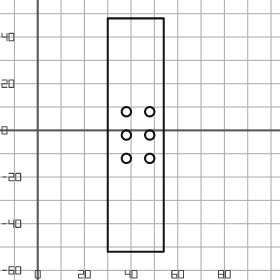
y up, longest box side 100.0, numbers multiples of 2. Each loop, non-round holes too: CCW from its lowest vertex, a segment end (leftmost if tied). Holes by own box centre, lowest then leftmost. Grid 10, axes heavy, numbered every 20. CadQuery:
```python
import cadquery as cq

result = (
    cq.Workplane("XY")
    .moveTo(30.0, -52.0)
    .lineTo(54.0, -52.0)
    .lineTo(54.0, 48.0)
    .lineTo(30.0, 48.0)
    .close()
    .moveTo(38.0, -12.0)
    .circle(2.0)
    .moveTo(48.0, -12.0)
    .circle(2.0)
    .moveTo(38.0, -2.0)
    .circle(2.0)
    .moveTo(48.0, -2.0)
    .circle(2.0)
    .moveTo(38.0, 8.0)
    .circle(2.0)
    .moveTo(48.0, 8.0)
    .circle(2.0)
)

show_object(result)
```